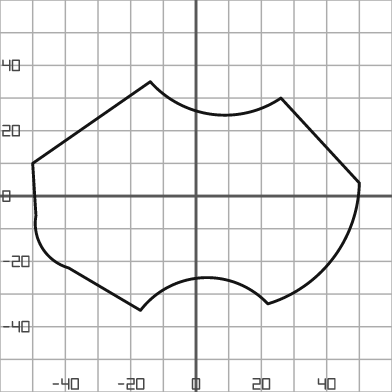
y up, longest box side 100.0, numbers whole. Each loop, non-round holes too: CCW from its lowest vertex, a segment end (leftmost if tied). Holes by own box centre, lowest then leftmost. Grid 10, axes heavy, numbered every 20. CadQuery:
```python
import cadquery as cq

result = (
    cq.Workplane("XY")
    .moveTo(-17.0, -35.0)
    .threePointArc((2.0, -25.0), (22.0, -33.0))
    .threePointArc((42.0, -19.0), (50.0, 4.0))
    .lineTo(26.0, 30.0)
    .threePointArc((5.0, 25.0), (-14.0, 35.0))
    .lineTo(-50.0, 10.0)
    .lineTo(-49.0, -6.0)
    .threePointArc((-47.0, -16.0), (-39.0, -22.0))
    .close()
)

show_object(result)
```